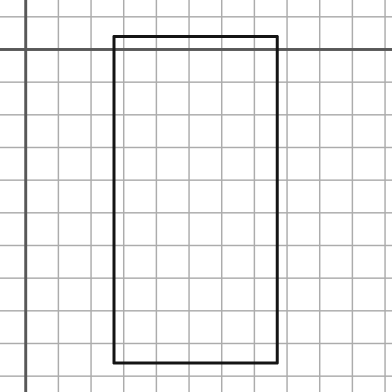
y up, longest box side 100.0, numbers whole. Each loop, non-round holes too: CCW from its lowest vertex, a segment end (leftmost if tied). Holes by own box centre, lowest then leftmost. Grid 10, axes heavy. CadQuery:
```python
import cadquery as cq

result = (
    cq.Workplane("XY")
    .moveTo(27.0, -96.0)
    .lineTo(77.0, -96.0)
    .lineTo(77.0, 4.0)
    .lineTo(27.0, 4.0)
    .close()
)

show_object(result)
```